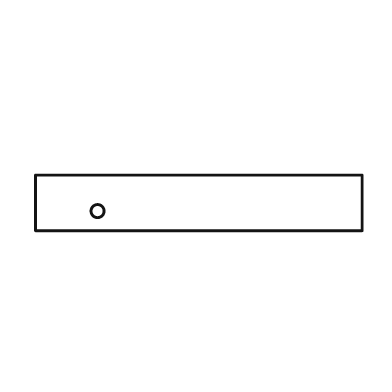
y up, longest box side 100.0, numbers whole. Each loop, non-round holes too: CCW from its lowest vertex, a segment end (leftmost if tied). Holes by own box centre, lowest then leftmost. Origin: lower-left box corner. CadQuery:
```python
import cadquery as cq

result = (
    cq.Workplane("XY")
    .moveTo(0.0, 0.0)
    .lineTo(100.0, 0.0)
    .lineTo(100.0, 17.0)
    .lineTo(0.0, 17.0)
    .close()
    .moveTo(19.0, 6.0)
    .circle(2.0)
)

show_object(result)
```